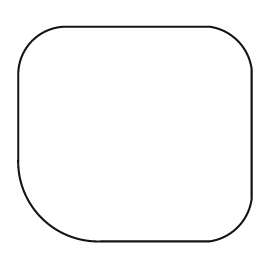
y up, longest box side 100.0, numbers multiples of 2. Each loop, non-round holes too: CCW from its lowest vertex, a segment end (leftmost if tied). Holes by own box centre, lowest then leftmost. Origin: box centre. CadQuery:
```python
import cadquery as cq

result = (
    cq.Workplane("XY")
    .moveTo(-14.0, -46.0)
    .lineTo(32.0, -46.0)
    .threePointArc((44.0, -40.0), (50.0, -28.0))
    .lineTo(50.0, 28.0)
    .threePointArc((44.0, 40.0), (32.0, 46.0))
    .lineTo(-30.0, 46.0)
    .threePointArc((-44.0, 40.0), (-50.0, 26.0))
    .lineTo(-50.0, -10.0)
    .threePointArc((-40.0, -36.0), (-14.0, -46.0))
    .close()
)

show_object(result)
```